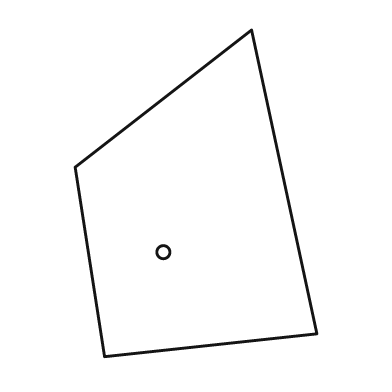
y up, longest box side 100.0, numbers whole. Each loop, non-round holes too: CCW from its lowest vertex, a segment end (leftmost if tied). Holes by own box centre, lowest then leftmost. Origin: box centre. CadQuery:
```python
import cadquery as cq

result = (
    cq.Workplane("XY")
    .moveTo(-28.0, -50.0)
    .lineTo(37.0, -43.0)
    .lineTo(17.0, 50.0)
    .lineTo(-37.0, 8.0)
    .close()
    .moveTo(-10.0, -18.0)
    .circle(2.0)
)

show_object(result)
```